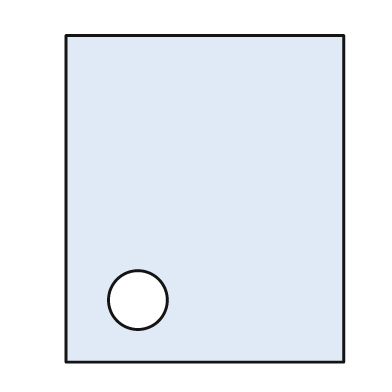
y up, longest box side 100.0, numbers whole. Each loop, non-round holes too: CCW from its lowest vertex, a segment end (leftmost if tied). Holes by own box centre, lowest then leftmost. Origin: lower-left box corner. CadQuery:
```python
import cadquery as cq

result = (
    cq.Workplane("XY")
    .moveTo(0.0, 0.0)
    .lineTo(85.0, 0.0)
    .lineTo(85.0, 100.0)
    .lineTo(0.0, 100.0)
    .close()
    .moveTo(22.0, 19.0)
    .circle(9.0)
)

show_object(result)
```